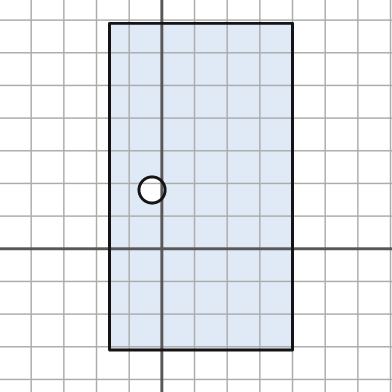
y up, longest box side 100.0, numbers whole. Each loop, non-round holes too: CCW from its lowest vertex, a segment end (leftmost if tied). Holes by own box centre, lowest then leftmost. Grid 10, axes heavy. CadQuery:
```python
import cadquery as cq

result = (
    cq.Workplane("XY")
    .moveTo(-16.0, -31.0)
    .lineTo(40.0, -31.0)
    .lineTo(40.0, 69.0)
    .lineTo(-16.0, 69.0)
    .close()
    .moveTo(-3.0, 18.0)
    .circle(4.0)
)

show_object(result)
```